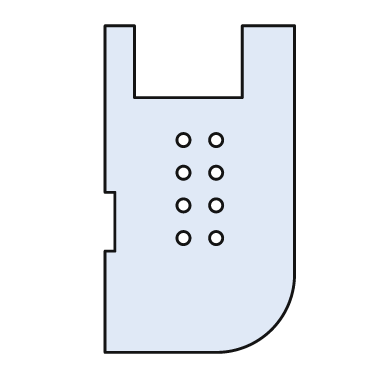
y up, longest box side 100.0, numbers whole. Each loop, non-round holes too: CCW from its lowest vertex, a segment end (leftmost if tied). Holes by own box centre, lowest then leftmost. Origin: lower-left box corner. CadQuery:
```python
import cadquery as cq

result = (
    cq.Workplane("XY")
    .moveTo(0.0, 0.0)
    .lineTo(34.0, 0.0)
    .threePointArc((51.0, 7.0), (58.0, 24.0))
    .lineTo(58.0, 100.0)
    .lineTo(42.0, 100.0)
    .lineTo(42.0, 78.0)
    .lineTo(9.0, 78.0)
    .lineTo(9.0, 100.0)
    .lineTo(0.0, 100.0)
    .lineTo(0.0, 49.0)
    .lineTo(3.0, 49.0)
    .lineTo(3.0, 31.0)
    .lineTo(0.0, 31.0)
    .close()
    .moveTo(24.0, 35.0)
    .circle(2.0)
    .moveTo(34.0, 35.0)
    .circle(2.0)
    .moveTo(24.0, 45.0)
    .circle(2.0)
    .moveTo(34.0, 45.0)
    .circle(2.0)
    .moveTo(24.0, 55.0)
    .circle(2.0)
    .moveTo(34.0, 55.0)
    .circle(2.0)
    .moveTo(24.0, 65.0)
    .circle(2.0)
    .moveTo(34.0, 65.0)
    .circle(2.0)
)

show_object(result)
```